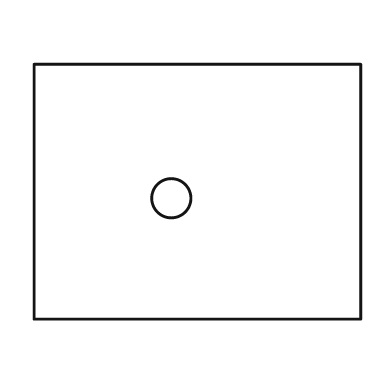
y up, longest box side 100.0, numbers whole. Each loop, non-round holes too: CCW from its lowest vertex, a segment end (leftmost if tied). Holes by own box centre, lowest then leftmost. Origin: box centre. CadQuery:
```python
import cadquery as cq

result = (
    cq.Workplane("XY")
    .moveTo(-50.0, -39.0)
    .lineTo(50.0, -39.0)
    .lineTo(50.0, 39.0)
    .lineTo(-50.0, 39.0)
    .close()
    .moveTo(-8.0, -2.0)
    .circle(6.0)
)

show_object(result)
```